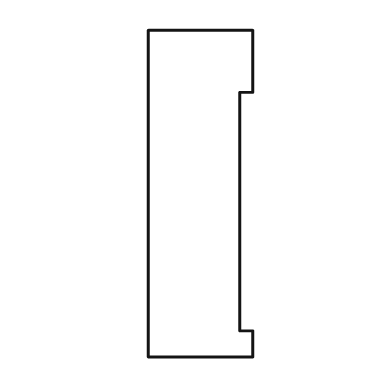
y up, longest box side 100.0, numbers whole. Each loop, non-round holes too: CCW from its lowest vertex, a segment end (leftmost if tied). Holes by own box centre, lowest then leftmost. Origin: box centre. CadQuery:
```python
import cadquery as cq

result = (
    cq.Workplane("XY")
    .moveTo(-16.0, -50.0)
    .lineTo(16.0, -50.0)
    .lineTo(16.0, -42.0)
    .lineTo(12.0, -42.0)
    .lineTo(12.0, 31.0)
    .lineTo(16.0, 31.0)
    .lineTo(16.0, 50.0)
    .lineTo(-16.0, 50.0)
    .close()
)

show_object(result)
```